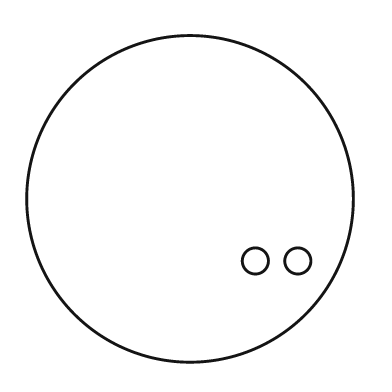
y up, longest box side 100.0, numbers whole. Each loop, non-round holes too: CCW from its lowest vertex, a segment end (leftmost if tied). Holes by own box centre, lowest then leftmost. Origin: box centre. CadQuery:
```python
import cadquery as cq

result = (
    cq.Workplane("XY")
    .moveTo(0.0, 0.0)
    .circle(50.0)
    .moveTo(20.0, -19.0)
    .circle(4.0)
    .moveTo(33.0, -19.0)
    .circle(4.0)
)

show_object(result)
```